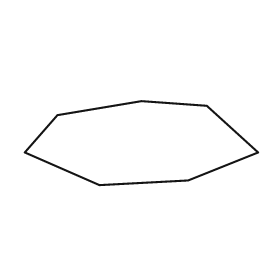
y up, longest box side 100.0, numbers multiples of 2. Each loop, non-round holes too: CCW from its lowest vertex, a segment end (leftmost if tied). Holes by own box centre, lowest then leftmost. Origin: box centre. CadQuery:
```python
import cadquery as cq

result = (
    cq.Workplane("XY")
    .moveTo(-18.0, -18.0)
    .lineTo(20.0, -16.0)
    .lineTo(50.0, -4.0)
    .lineTo(28.0, 16.0)
    .lineTo(0.0, 18.0)
    .lineTo(-36.0, 12.0)
    .lineTo(-50.0, -4.0)
    .close()
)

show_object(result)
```